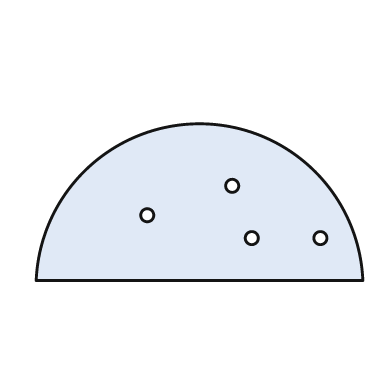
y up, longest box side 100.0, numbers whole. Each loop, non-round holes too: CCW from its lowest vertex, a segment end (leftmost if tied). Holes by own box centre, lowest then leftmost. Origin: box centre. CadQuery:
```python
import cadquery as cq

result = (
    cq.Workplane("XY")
    .moveTo(-50.0, -24.0)
    .lineTo(50.0, -24.0)
    .threePointArc((0.0, 24.0), (-50.0, -24.0))
    .close()
    .moveTo(16.0, -11.0)
    .circle(2.0)
    .moveTo(37.0, -11.0)
    .circle(2.0)
    .moveTo(-16.0, -4.0)
    .circle(2.0)
    .moveTo(10.0, 5.0)
    .circle(2.0)
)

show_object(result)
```